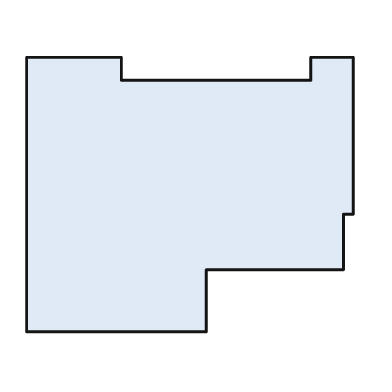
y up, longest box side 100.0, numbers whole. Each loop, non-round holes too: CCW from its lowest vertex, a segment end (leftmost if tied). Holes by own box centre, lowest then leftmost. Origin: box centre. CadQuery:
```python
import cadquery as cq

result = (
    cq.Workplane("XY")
    .moveTo(-50.0, -42.0)
    .lineTo(5.0, -42.0)
    .lineTo(5.0, -23.0)
    .lineTo(47.0, -23.0)
    .lineTo(47.0, -6.0)
    .lineTo(50.0, -6.0)
    .lineTo(50.0, 42.0)
    .lineTo(37.0, 42.0)
    .lineTo(37.0, 35.0)
    .lineTo(-21.0, 35.0)
    .lineTo(-21.0, 42.0)
    .lineTo(-50.0, 42.0)
    .close()
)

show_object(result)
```